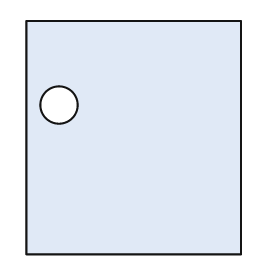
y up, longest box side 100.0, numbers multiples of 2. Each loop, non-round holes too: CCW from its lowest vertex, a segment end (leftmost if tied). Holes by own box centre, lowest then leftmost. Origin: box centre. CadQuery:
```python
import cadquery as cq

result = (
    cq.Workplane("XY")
    .moveTo(-46.0, -50.0)
    .lineTo(46.0, -50.0)
    .lineTo(46.0, 50.0)
    .lineTo(-46.0, 50.0)
    .close()
    .moveTo(-32.0, 14.0)
    .circle(8.0)
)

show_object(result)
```